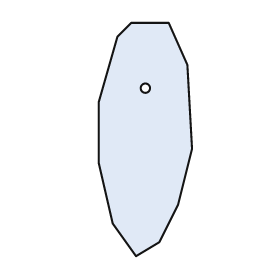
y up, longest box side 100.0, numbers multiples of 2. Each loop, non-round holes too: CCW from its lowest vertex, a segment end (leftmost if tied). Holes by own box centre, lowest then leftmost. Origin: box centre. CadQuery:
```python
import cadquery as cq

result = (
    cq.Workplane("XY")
    .moveTo(-4.0, -50.0)
    .lineTo(6.0, -44.0)
    .lineTo(14.0, -28.0)
    .lineTo(20.0, -4.0)
    .lineTo(18.0, 32.0)
    .lineTo(10.0, 50.0)
    .lineTo(-6.0, 50.0)
    .lineTo(-12.0, 44.0)
    .lineTo(-20.0, 16.0)
    .lineTo(-20.0, -10.0)
    .lineTo(-14.0, -36.0)
    .close()
    .moveTo(0.0, 22.0)
    .circle(2.0)
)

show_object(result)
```